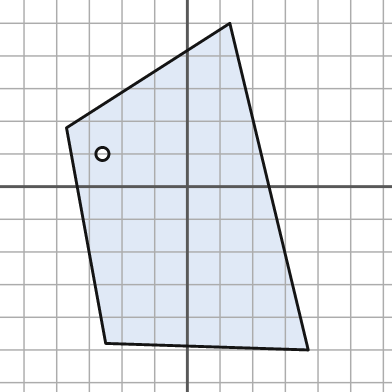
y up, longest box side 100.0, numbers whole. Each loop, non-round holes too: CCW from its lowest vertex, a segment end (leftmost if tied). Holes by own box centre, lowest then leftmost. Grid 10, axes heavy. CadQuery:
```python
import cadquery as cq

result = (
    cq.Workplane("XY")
    .moveTo(37.0, -50.0)
    .lineTo(13.0, 50.0)
    .lineTo(-37.0, 18.0)
    .lineTo(-25.0, -48.0)
    .close()
    .moveTo(-26.0, 10.0)
    .circle(2.0)
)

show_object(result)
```